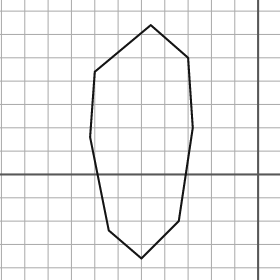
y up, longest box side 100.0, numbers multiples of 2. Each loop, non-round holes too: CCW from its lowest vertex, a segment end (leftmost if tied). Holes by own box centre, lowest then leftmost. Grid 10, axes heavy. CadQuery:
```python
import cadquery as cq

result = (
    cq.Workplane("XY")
    .moveTo(-50.0, -36.0)
    .lineTo(-34.0, -20.0)
    .lineTo(-28.0, 20.0)
    .lineTo(-30.0, 50.0)
    .lineTo(-46.0, 64.0)
    .lineTo(-70.0, 44.0)
    .lineTo(-72.0, 16.0)
    .lineTo(-64.0, -24.0)
    .close()
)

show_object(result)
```